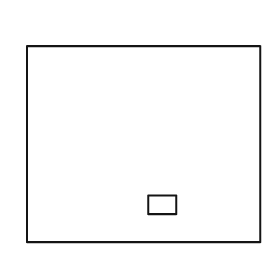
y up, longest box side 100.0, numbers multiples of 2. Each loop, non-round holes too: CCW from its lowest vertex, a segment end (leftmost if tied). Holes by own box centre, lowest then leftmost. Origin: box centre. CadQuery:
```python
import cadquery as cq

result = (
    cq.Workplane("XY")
    .moveTo(-50.0, -42.0)
    .lineTo(50.0, -42.0)
    .lineTo(50.0, 42.0)
    .lineTo(-50.0, 42.0)
    .close()
    .moveTo(2.0, -30.0)
    .lineTo(14.0, -30.0)
    .lineTo(14.0, -22.0)
    .lineTo(2.0, -22.0)
    .close()
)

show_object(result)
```